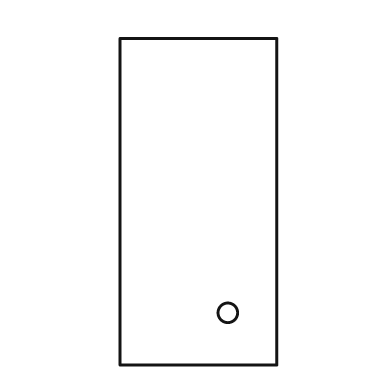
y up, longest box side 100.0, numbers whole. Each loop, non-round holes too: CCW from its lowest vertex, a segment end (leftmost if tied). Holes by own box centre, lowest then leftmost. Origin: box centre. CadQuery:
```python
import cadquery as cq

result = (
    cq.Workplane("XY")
    .moveTo(-24.0, -50.0)
    .lineTo(24.0, -50.0)
    .lineTo(24.0, 50.0)
    .lineTo(-24.0, 50.0)
    .close()
    .moveTo(9.0, -34.0)
    .circle(3.0)
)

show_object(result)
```